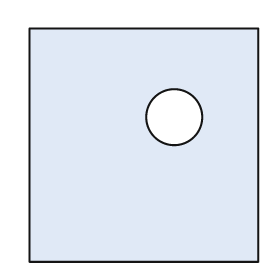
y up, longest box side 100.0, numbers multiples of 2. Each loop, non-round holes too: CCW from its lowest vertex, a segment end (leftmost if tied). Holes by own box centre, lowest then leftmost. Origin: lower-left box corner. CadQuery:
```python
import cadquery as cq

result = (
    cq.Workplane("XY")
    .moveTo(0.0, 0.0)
    .lineTo(98.0, 0.0)
    .lineTo(98.0, 100.0)
    .lineTo(0.0, 100.0)
    .close()
    .moveTo(62.0, 62.0)
    .circle(12.0)
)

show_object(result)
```